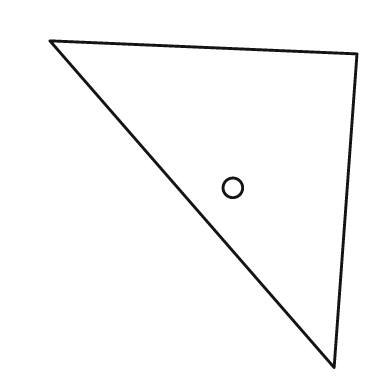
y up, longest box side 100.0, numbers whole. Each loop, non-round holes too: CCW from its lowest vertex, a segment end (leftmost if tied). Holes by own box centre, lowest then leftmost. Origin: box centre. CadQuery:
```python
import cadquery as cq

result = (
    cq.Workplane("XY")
    .moveTo(40.0, -50.0)
    .lineTo(47.0, 46.0)
    .lineTo(-47.0, 50.0)
    .close()
    .moveTo(9.0, 5.0)
    .circle(3.0)
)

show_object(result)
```